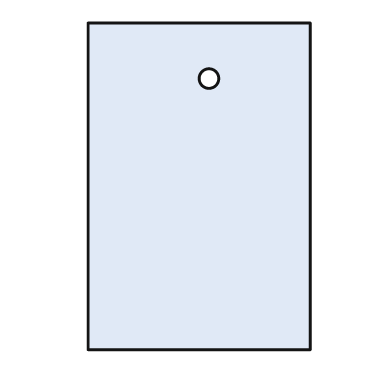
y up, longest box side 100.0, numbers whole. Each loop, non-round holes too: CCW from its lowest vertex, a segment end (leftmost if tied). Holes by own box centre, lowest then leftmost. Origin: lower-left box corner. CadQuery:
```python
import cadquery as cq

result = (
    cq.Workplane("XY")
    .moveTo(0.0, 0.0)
    .lineTo(68.0, 0.0)
    .lineTo(68.0, 100.0)
    .lineTo(0.0, 100.0)
    .close()
    .moveTo(37.0, 83.0)
    .circle(3.0)
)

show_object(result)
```